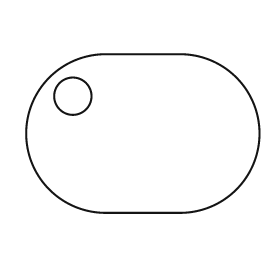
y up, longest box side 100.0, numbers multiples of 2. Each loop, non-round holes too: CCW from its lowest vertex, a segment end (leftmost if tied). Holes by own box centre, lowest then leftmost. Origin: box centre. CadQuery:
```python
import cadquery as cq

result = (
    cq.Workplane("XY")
    .moveTo(-16.0, -34.0)
    .lineTo(16.0, -34.0)
    .threePointArc((50.0, 0.0), (16.0, 34.0))
    .lineTo(-16.0, 34.0)
    .threePointArc((-50.0, 0.0), (-16.0, -34.0))
    .close()
    .moveTo(-30.0, 16.0)
    .circle(8.0)
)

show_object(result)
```